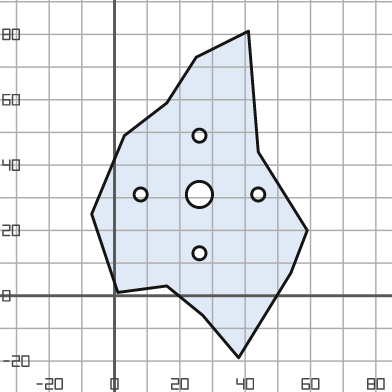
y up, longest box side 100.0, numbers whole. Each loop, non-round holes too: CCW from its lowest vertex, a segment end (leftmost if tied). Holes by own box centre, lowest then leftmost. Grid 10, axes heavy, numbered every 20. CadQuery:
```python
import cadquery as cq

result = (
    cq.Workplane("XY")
    .moveTo(38.0, -19.0)
    .lineTo(54.0, 7.0)
    .lineTo(59.0, 20.0)
    .lineTo(44.0, 44.0)
    .lineTo(41.0, 81.0)
    .lineTo(25.0, 73.0)
    .lineTo(16.0, 59.0)
    .lineTo(3.0, 49.0)
    .lineTo(-7.0, 25.0)
    .lineTo(1.0, 1.0)
    .lineTo(16.0, 3.0)
    .lineTo(27.0, -6.0)
    .close()
    .moveTo(26.0, 13.0)
    .circle(2.0)
    .moveTo(8.0, 31.0)
    .circle(2.0)
    .moveTo(26.0, 31.0)
    .circle(4.0)
    .moveTo(44.0, 31.0)
    .circle(2.0)
    .moveTo(26.0, 49.0)
    .circle(2.0)
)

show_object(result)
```